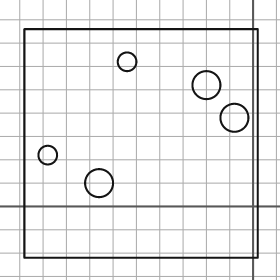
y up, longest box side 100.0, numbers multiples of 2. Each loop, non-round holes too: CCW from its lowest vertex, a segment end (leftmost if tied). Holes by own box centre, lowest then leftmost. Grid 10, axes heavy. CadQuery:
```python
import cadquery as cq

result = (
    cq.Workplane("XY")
    .moveTo(-98.0, -22.0)
    .lineTo(2.0, -22.0)
    .lineTo(2.0, 76.0)
    .lineTo(-98.0, 76.0)
    .close()
    .moveTo(-66.0, 10.0)
    .circle(6.0)
    .moveTo(-88.0, 22.0)
    .circle(4.0)
    .moveTo(-8.0, 38.0)
    .circle(6.0)
    .moveTo(-20.0, 52.0)
    .circle(6.0)
    .moveTo(-54.0, 62.0)
    .circle(4.0)
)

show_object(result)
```